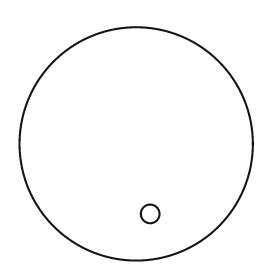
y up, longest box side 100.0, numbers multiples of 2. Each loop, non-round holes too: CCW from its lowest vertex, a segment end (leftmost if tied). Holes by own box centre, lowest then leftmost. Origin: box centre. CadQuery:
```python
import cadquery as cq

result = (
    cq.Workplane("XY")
    .moveTo(0.0, 0.0)
    .circle(50.0)
    .moveTo(6.0, -30.0)
    .circle(4.0)
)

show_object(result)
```